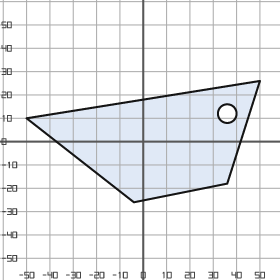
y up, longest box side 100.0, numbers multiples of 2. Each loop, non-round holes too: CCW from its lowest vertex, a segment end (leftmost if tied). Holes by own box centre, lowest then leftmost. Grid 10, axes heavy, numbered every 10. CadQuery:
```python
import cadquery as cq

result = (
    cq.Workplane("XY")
    .moveTo(-4.0, -26.0)
    .lineTo(36.0, -18.0)
    .lineTo(50.0, 26.0)
    .lineTo(-50.0, 10.0)
    .close()
    .moveTo(36.0, 12.0)
    .circle(4.0)
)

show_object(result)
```